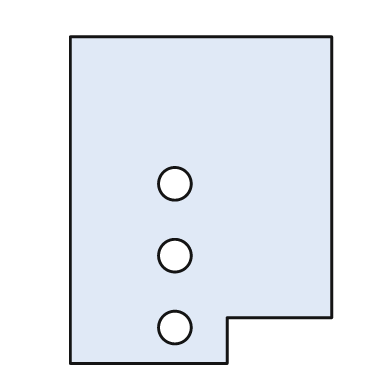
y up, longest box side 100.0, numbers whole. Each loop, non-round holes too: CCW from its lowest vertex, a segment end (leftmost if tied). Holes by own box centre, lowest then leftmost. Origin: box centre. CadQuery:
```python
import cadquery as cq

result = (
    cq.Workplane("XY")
    .moveTo(-40.0, -50.0)
    .lineTo(8.0, -50.0)
    .lineTo(8.0, -36.0)
    .lineTo(40.0, -36.0)
    .lineTo(40.0, 50.0)
    .lineTo(-40.0, 50.0)
    .close()
    .moveTo(-8.0, -39.0)
    .circle(5.0)
    .moveTo(-8.0, -17.0)
    .circle(5.0)
    .moveTo(-8.0, 5.0)
    .circle(5.0)
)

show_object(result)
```